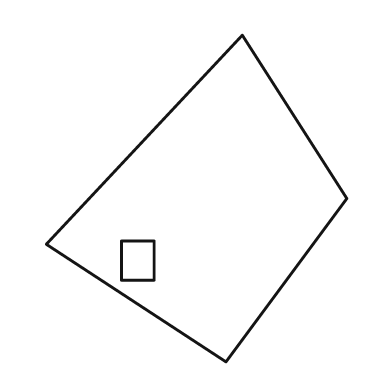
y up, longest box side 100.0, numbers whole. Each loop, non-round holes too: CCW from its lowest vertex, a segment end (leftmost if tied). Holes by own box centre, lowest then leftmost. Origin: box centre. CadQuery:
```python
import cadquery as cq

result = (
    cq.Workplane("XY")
    .moveTo(9.0, -50.0)
    .lineTo(46.0, 0.0)
    .lineTo(14.0, 50.0)
    .lineTo(-46.0, -14.0)
    .close()
    .moveTo(-23.0, -25.0)
    .lineTo(-13.0, -25.0)
    .lineTo(-13.0, -13.0)
    .lineTo(-23.0, -13.0)
    .close()
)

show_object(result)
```